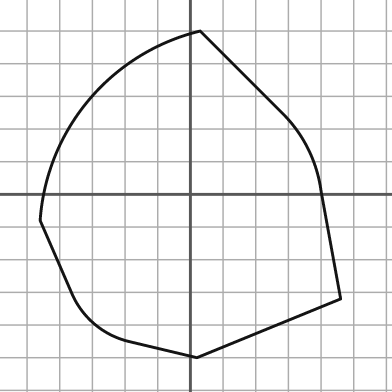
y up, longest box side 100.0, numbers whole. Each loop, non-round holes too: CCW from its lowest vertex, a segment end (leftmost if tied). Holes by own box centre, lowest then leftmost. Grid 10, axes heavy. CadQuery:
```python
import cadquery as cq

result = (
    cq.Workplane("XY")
    .moveTo(2.0, -50.0)
    .lineTo(46.0, -32.0)
    .lineTo(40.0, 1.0)
    .threePointArc((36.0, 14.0), (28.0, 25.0))
    .lineTo(3.0, 50.0)
    .threePointArc((-31.0, 29.0), (-46.0, -8.0))
    .lineTo(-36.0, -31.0)
    .threePointArc((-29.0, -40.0), (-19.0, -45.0))
    .close()
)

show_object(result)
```